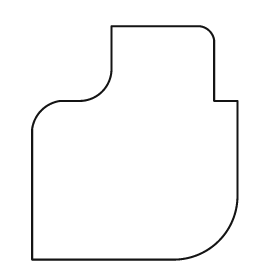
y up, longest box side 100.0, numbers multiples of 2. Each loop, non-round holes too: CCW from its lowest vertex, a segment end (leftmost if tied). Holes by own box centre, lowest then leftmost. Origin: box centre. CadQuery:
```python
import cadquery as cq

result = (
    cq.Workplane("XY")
    .moveTo(-44.0, -50.0)
    .lineTo(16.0, -50.0)
    .threePointArc((36.0, -42.0), (44.0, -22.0))
    .lineTo(44.0, 18.0)
    .lineTo(34.0, 18.0)
    .lineTo(34.0, 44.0)
    .threePointArc((32.0, 48.0), (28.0, 50.0))
    .lineTo(-10.0, 50.0)
    .lineTo(-10.0, 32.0)
    .threePointArc((-14.0, 22.0), (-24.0, 18.0))
    .lineTo(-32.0, 18.0)
    .threePointArc((-40.0, 14.0), (-44.0, 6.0))
    .close()
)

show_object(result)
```